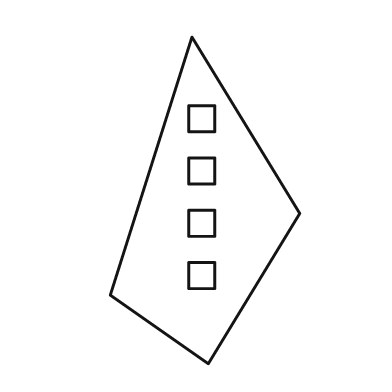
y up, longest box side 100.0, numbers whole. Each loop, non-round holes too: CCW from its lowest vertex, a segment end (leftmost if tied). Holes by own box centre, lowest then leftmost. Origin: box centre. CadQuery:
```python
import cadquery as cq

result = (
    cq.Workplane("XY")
    .moveTo(1.0, -50.0)
    .lineTo(29.0, -4.0)
    .lineTo(-4.0, 50.0)
    .lineTo(-29.0, -29.0)
    .close()
    .moveTo(-5.0, -27.0)
    .lineTo(3.0, -27.0)
    .lineTo(3.0, -19.0)
    .lineTo(-5.0, -19.0)
    .close()
    .moveTo(-5.0, -11.0)
    .lineTo(3.0, -11.0)
    .lineTo(3.0, -3.0)
    .lineTo(-5.0, -3.0)
    .close()
    .moveTo(-5.0, 5.0)
    .lineTo(3.0, 5.0)
    .lineTo(3.0, 13.0)
    .lineTo(-5.0, 13.0)
    .close()
    .moveTo(-5.0, 21.0)
    .lineTo(3.0, 21.0)
    .lineTo(3.0, 29.0)
    .lineTo(-5.0, 29.0)
    .close()
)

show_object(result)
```